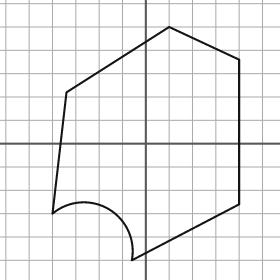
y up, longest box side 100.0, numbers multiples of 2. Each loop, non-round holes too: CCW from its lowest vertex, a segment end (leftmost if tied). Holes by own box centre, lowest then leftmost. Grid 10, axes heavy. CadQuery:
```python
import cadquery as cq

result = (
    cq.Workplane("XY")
    .moveTo(-6.0, -50.0)
    .lineTo(40.0, -26.0)
    .lineTo(40.0, 36.0)
    .lineTo(10.0, 50.0)
    .lineTo(-34.0, 22.0)
    .lineTo(-40.0, -30.0)
    .threePointArc((-16.0, -28.0), (-6.0, -50.0))
    .close()
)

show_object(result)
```